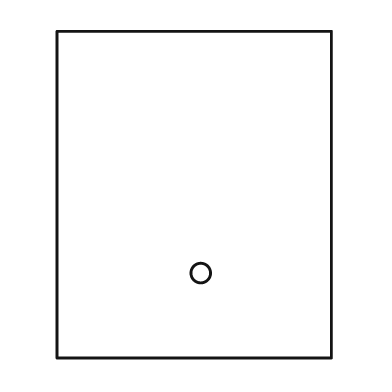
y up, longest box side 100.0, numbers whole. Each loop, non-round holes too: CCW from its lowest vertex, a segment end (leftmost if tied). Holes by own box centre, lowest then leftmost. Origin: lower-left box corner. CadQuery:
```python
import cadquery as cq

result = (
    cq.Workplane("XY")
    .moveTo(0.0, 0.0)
    .lineTo(84.0, 0.0)
    .lineTo(84.0, 100.0)
    .lineTo(0.0, 100.0)
    .close()
    .moveTo(44.0, 26.0)
    .circle(3.0)
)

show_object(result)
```